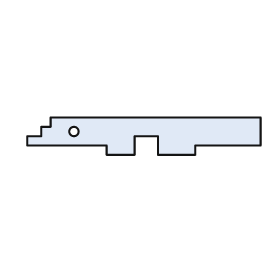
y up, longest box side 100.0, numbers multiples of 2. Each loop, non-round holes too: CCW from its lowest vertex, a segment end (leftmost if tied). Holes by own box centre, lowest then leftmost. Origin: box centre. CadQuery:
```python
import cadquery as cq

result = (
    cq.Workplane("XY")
    .moveTo(-16.0, -8.0)
    .lineTo(-4.0, -8.0)
    .lineTo(-4.0, 0.0)
    .lineTo(6.0, 0.0)
    .lineTo(6.0, -8.0)
    .lineTo(22.0, -8.0)
    .lineTo(22.0, -4.0)
    .lineTo(50.0, -4.0)
    .lineTo(50.0, 8.0)
    .lineTo(-40.0, 8.0)
    .lineTo(-40.0, 4.0)
    .lineTo(-44.0, 4.0)
    .lineTo(-44.0, 0.0)
    .lineTo(-50.0, 0.0)
    .lineTo(-50.0, -4.0)
    .lineTo(-16.0, -4.0)
    .close()
    .moveTo(-30.0, 2.0)
    .circle(2.0)
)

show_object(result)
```